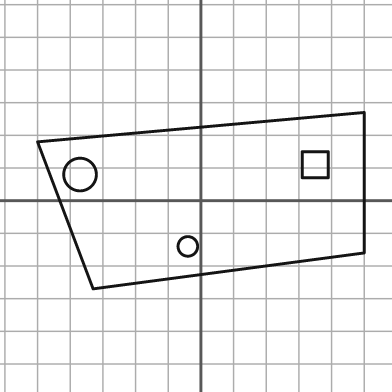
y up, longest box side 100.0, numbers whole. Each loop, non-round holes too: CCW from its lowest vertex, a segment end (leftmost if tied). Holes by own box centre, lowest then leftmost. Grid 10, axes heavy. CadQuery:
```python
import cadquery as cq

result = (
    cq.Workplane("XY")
    .moveTo(-33.0, -27.0)
    .lineTo(50.0, -16.0)
    .lineTo(50.0, 27.0)
    .lineTo(-50.0, 18.0)
    .close()
    .moveTo(-4.0, -14.0)
    .circle(3.0)
    .moveTo(-37.0, 8.0)
    .circle(5.0)
    .moveTo(31.0, 7.0)
    .lineTo(39.0, 7.0)
    .lineTo(39.0, 15.0)
    .lineTo(31.0, 15.0)
    .close()
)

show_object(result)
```